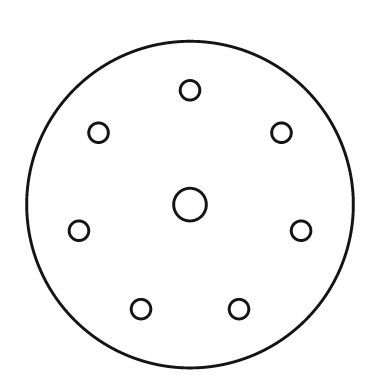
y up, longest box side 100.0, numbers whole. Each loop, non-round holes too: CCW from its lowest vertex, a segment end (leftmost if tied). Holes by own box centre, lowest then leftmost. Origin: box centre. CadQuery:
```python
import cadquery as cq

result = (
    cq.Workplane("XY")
    .moveTo(0.0, 0.0)
    .circle(50.0)
    .moveTo(-15.0, -32.0)
    .circle(3.0)
    .moveTo(15.0, -32.0)
    .circle(3.0)
    .moveTo(-34.0, -8.0)
    .circle(3.0)
    .moveTo(34.0, -8.0)
    .circle(3.0)
    .moveTo(0.0, 0.0)
    .circle(5.0)
    .moveTo(-28.0, 22.0)
    .circle(3.0)
    .moveTo(28.0, 22.0)
    .circle(3.0)
    .moveTo(0.0, 35.0)
    .circle(3.0)
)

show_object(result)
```